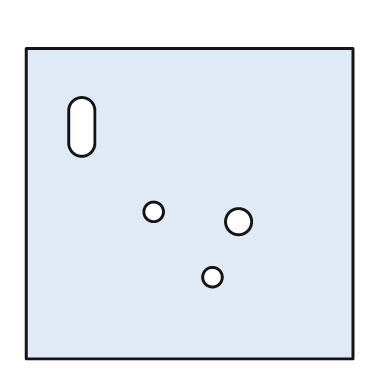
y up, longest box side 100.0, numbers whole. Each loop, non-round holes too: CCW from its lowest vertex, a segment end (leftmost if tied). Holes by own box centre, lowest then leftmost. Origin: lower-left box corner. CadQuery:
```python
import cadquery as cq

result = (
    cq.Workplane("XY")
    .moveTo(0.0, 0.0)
    .lineTo(100.0, 0.0)
    .lineTo(100.0, 95.0)
    .lineTo(0.0, 95.0)
    .close()
    .moveTo(57.0, 25.0)
    .circle(3.0)
    .moveTo(65.0, 42.0)
    .circle(4.0)
    .moveTo(39.0, 45.0)
    .circle(3.0)
    .moveTo(13.0, 66.0)
    .threePointArc((17.0, 62.0), (21.0, 66.0))
    .lineTo(21.0, 76.0)
    .threePointArc((17.0, 80.0), (13.0, 76.0))
    .close()
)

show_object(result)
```